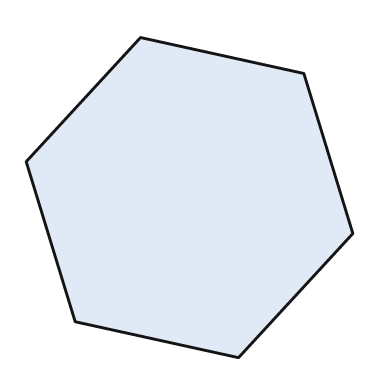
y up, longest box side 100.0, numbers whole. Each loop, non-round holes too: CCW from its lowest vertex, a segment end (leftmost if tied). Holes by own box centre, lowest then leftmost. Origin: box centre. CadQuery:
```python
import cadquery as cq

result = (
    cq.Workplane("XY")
    .moveTo(15.0, -49.0)
    .lineTo(50.0, -11.0)
    .lineTo(35.0, 38.0)
    .lineTo(-15.0, 49.0)
    .lineTo(-50.0, 11.0)
    .lineTo(-35.0, -38.0)
    .close()
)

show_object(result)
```